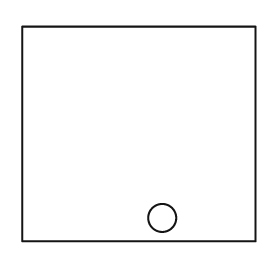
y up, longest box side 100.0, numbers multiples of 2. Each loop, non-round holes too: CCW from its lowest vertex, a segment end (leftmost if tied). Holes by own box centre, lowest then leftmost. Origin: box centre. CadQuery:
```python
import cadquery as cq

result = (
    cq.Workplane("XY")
    .moveTo(-50.0, -46.0)
    .lineTo(50.0, -46.0)
    .lineTo(50.0, 46.0)
    .lineTo(-50.0, 46.0)
    .close()
    .moveTo(10.0, -36.0)
    .circle(6.0)
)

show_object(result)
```